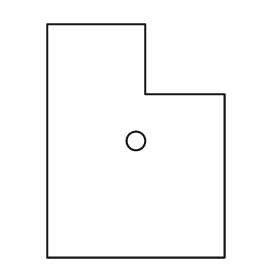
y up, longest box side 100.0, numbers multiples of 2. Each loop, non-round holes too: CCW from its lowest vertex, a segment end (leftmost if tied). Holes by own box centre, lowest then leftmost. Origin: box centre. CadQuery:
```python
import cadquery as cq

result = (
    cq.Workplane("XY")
    .moveTo(-38.0, -50.0)
    .lineTo(38.0, -50.0)
    .lineTo(38.0, 20.0)
    .lineTo(4.0, 20.0)
    .lineTo(4.0, 50.0)
    .lineTo(-38.0, 50.0)
    .close()
    .moveTo(0.0, 0.0)
    .circle(4.0)
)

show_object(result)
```